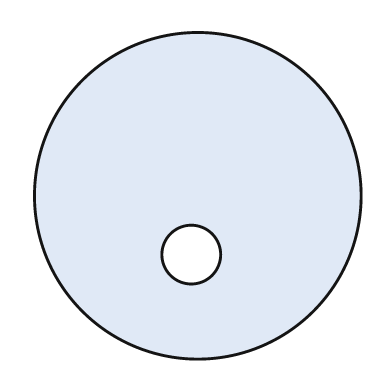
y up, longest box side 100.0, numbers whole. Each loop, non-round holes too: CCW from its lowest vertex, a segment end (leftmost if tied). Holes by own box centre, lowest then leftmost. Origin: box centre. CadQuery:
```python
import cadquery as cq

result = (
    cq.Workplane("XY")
    .moveTo(0.0, 0.0)
    .circle(50.0)
    .moveTo(-2.0, -18.0)
    .circle(9.0)
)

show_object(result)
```